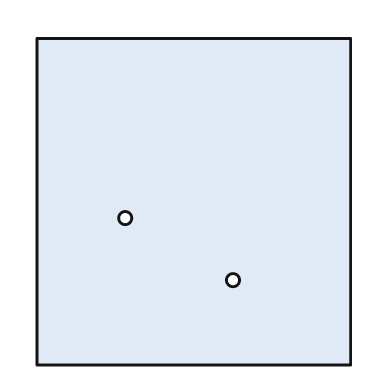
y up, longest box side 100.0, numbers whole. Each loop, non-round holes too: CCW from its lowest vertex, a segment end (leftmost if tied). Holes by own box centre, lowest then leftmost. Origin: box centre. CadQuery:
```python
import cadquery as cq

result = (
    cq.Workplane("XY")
    .moveTo(-48.0, -50.0)
    .lineTo(48.0, -50.0)
    .lineTo(48.0, 50.0)
    .lineTo(-48.0, 50.0)
    .close()
    .moveTo(12.0, -24.0)
    .circle(2.0)
    .moveTo(-21.0, -5.0)
    .circle(2.0)
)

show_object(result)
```